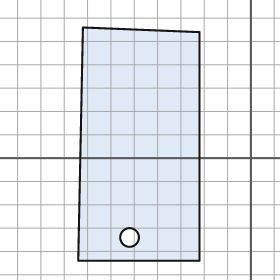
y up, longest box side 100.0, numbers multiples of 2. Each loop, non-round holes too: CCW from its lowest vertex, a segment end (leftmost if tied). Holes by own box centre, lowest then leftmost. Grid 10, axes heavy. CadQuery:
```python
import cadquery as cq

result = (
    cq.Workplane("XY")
    .moveTo(-74.0, -44.0)
    .lineTo(-22.0, -44.0)
    .lineTo(-22.0, 54.0)
    .lineTo(-72.0, 56.0)
    .close()
    .moveTo(-52.0, -34.0)
    .circle(4.0)
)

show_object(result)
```